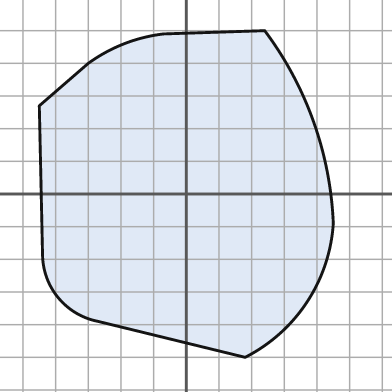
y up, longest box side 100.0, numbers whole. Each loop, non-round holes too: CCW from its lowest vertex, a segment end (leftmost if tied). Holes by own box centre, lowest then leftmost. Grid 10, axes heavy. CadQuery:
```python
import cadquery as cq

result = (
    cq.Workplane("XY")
    .moveTo(18.0, -50.0)
    .threePointArc((37.0, -33.0), (45.0, -9.0))
    .threePointArc((39.0, 22.0), (24.0, 50.0))
    .lineTo(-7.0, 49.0)
    .threePointArc((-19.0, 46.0), (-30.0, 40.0))
    .lineTo(-45.0, 27.0)
    .lineTo(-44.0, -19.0)
    .threePointArc((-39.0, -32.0), (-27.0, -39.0))
    .close()
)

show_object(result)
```